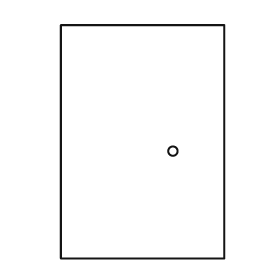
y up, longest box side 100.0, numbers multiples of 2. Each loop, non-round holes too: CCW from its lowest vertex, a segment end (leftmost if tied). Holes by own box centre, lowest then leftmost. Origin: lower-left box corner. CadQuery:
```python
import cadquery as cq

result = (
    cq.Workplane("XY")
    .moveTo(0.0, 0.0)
    .lineTo(70.0, 0.0)
    .lineTo(70.0, 100.0)
    .lineTo(0.0, 100.0)
    .close()
    .moveTo(48.0, 46.0)
    .circle(2.0)
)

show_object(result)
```